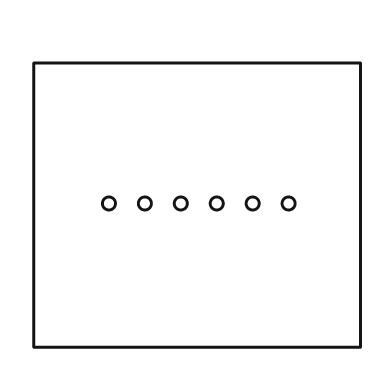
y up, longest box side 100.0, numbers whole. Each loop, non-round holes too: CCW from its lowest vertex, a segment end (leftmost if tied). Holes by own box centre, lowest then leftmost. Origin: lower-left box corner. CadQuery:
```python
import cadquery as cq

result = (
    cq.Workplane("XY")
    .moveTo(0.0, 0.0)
    .lineTo(100.0, 0.0)
    .lineTo(100.0, 87.0)
    .lineTo(0.0, 87.0)
    .close()
    .moveTo(23.0, 44.0)
    .circle(2.0)
    .moveTo(34.0, 44.0)
    .circle(2.0)
    .moveTo(45.0, 44.0)
    .circle(2.0)
    .moveTo(56.0, 44.0)
    .circle(2.0)
    .moveTo(67.0, 44.0)
    .circle(2.0)
    .moveTo(78.0, 44.0)
    .circle(2.0)
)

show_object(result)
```